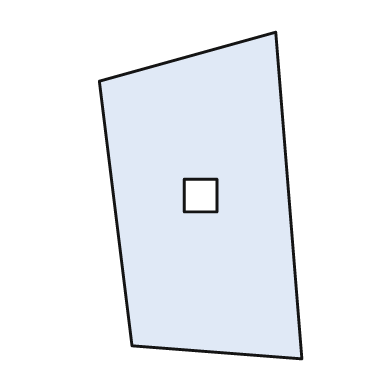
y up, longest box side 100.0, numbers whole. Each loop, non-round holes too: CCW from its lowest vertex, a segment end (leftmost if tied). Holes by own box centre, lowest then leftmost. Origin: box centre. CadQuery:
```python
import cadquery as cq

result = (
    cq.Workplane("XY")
    .moveTo(31.0, -50.0)
    .lineTo(23.0, 50.0)
    .lineTo(-31.0, 35.0)
    .lineTo(-21.0, -46.0)
    .close()
    .moveTo(-5.0, -5.0)
    .lineTo(5.0, -5.0)
    .lineTo(5.0, 5.0)
    .lineTo(-5.0, 5.0)
    .close()
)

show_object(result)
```